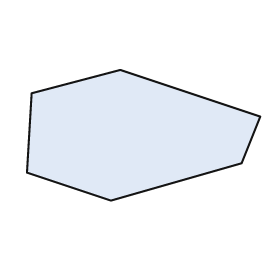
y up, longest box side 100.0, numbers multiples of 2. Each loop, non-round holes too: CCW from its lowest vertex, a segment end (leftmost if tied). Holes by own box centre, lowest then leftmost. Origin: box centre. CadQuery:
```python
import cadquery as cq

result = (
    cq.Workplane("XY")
    .moveTo(-14.0, -28.0)
    .lineTo(42.0, -12.0)
    .lineTo(50.0, 8.0)
    .lineTo(-10.0, 28.0)
    .lineTo(-48.0, 18.0)
    .lineTo(-50.0, -16.0)
    .close()
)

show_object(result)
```